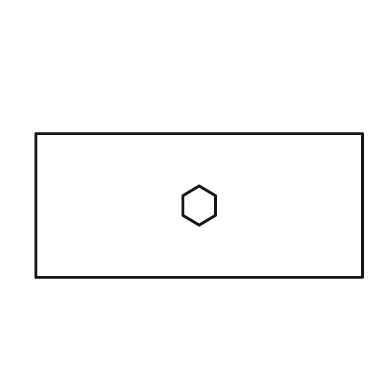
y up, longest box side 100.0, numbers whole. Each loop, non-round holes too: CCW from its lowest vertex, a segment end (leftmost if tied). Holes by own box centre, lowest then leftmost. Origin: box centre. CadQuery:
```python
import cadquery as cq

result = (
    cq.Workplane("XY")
    .moveTo(-50.0, -22.0)
    .lineTo(50.0, -22.0)
    .lineTo(50.0, 22.0)
    .lineTo(-50.0, 22.0)
    .close()
    .moveTo(0.0, -6.0)
    .lineTo(5.0, -3.0)
    .lineTo(5.0, 3.0)
    .lineTo(0.0, 6.0)
    .lineTo(-5.0, 3.0)
    .lineTo(-5.0, -3.0)
    .close()
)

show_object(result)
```